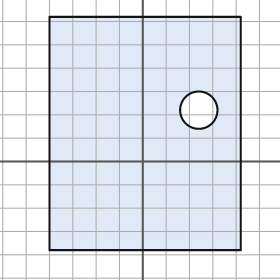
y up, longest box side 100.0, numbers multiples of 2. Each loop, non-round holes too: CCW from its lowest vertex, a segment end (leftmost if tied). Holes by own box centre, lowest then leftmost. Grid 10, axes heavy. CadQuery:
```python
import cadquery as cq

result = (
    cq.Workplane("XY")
    .moveTo(-40.0, -38.0)
    .lineTo(42.0, -38.0)
    .lineTo(42.0, 62.0)
    .lineTo(-40.0, 62.0)
    .close()
    .moveTo(24.0, 22.0)
    .circle(8.0)
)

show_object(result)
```